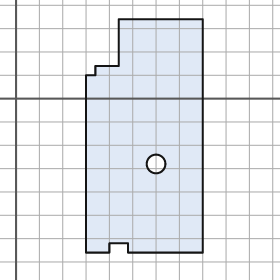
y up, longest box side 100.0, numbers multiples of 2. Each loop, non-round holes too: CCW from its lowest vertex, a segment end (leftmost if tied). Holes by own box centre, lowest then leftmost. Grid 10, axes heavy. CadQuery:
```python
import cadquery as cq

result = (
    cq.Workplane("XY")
    .moveTo(30.0, -66.0)
    .lineTo(40.0, -66.0)
    .lineTo(40.0, -62.0)
    .lineTo(48.0, -62.0)
    .lineTo(48.0, -66.0)
    .lineTo(80.0, -66.0)
    .lineTo(80.0, 34.0)
    .lineTo(44.0, 34.0)
    .lineTo(44.0, 14.0)
    .lineTo(34.0, 14.0)
    .lineTo(34.0, 10.0)
    .lineTo(30.0, 10.0)
    .close()
    .moveTo(60.0, -28.0)
    .circle(4.0)
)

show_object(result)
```